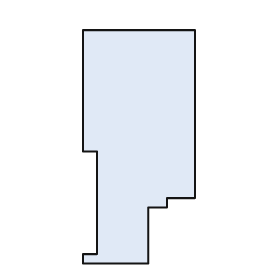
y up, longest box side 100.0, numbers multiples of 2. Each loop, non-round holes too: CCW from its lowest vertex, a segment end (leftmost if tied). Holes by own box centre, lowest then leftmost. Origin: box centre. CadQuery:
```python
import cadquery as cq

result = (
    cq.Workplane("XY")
    .moveTo(-24.0, -50.0)
    .lineTo(4.0, -50.0)
    .lineTo(4.0, -26.0)
    .lineTo(12.0, -26.0)
    .lineTo(12.0, -22.0)
    .lineTo(24.0, -22.0)
    .lineTo(24.0, 50.0)
    .lineTo(-24.0, 50.0)
    .lineTo(-24.0, -2.0)
    .lineTo(-18.0, -2.0)
    .lineTo(-18.0, -46.0)
    .lineTo(-24.0, -46.0)
    .close()
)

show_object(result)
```